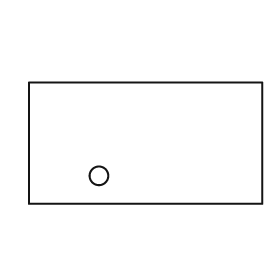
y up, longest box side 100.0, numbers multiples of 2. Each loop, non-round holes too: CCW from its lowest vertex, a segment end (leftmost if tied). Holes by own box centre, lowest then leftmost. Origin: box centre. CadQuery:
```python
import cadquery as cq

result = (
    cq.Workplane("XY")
    .moveTo(-50.0, -26.0)
    .lineTo(50.0, -26.0)
    .lineTo(50.0, 26.0)
    .lineTo(-50.0, 26.0)
    .close()
    .moveTo(-20.0, -14.0)
    .circle(4.0)
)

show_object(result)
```